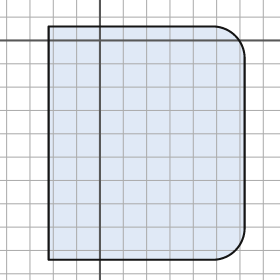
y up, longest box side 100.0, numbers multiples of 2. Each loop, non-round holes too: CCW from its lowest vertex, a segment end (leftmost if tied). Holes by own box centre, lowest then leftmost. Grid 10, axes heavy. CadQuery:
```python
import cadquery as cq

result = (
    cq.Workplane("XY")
    .moveTo(-22.0, -94.0)
    .lineTo(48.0, -94.0)
    .threePointArc((58.0, -90.0), (62.0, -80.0))
    .lineTo(62.0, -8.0)
    .threePointArc((58.0, 2.0), (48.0, 6.0))
    .lineTo(-22.0, 6.0)
    .close()
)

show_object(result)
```